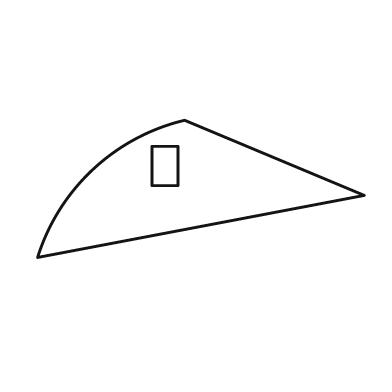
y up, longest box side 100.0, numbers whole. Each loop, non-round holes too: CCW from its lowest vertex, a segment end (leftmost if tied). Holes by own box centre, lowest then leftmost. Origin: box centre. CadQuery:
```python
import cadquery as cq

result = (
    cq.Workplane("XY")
    .moveTo(-50.0, -21.0)
    .lineTo(50.0, -2.0)
    .lineTo(-5.0, 21.0)
    .threePointArc((-33.0, 6.0), (-50.0, -21.0))
    .close()
    .moveTo(-15.0, 1.0)
    .lineTo(-7.0, 1.0)
    .lineTo(-7.0, 13.0)
    .lineTo(-15.0, 13.0)
    .close()
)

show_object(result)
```